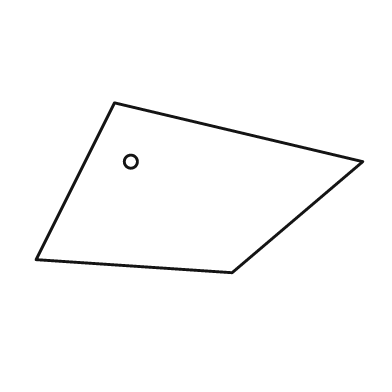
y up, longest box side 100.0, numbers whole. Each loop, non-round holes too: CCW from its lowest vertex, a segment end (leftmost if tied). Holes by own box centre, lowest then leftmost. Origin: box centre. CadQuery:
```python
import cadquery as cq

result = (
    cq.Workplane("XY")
    .moveTo(10.0, -26.0)
    .lineTo(50.0, 8.0)
    .lineTo(-26.0, 26.0)
    .lineTo(-50.0, -22.0)
    .close()
    .moveTo(-21.0, 8.0)
    .circle(2.0)
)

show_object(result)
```